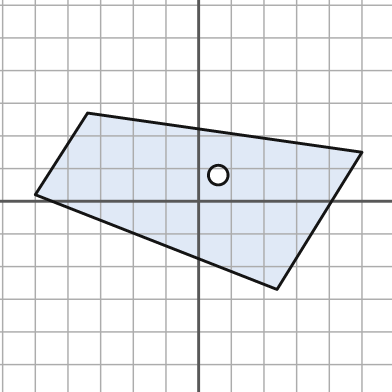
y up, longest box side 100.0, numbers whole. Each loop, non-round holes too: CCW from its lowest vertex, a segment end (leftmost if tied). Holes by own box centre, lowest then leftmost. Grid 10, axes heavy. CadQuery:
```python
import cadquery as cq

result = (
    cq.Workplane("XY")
    .moveTo(24.0, -27.0)
    .lineTo(50.0, 15.0)
    .lineTo(-34.0, 27.0)
    .lineTo(-50.0, 2.0)
    .close()
    .moveTo(6.0, 8.0)
    .circle(3.0)
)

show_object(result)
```